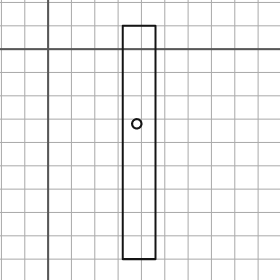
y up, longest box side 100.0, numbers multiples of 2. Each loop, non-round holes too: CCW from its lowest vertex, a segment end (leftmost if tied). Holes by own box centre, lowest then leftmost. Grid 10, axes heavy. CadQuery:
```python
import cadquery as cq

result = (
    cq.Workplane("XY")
    .moveTo(32.0, -90.0)
    .lineTo(46.0, -90.0)
    .lineTo(46.0, 10.0)
    .lineTo(32.0, 10.0)
    .close()
    .moveTo(38.0, -32.0)
    .circle(2.0)
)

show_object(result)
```